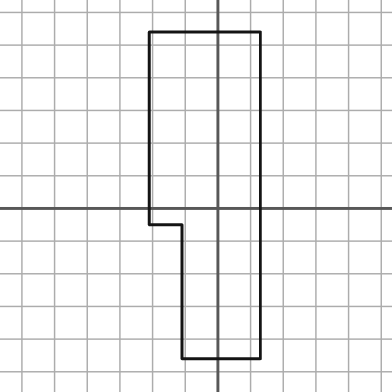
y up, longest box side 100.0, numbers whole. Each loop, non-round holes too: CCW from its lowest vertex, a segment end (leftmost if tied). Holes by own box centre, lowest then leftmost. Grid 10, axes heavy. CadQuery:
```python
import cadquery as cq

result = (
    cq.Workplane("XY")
    .moveTo(-11.0, -46.0)
    .lineTo(13.0, -46.0)
    .lineTo(13.0, 54.0)
    .lineTo(-21.0, 54.0)
    .lineTo(-21.0, -5.0)
    .lineTo(-11.0, -5.0)
    .close()
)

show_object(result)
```